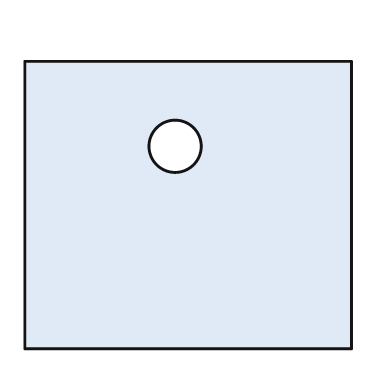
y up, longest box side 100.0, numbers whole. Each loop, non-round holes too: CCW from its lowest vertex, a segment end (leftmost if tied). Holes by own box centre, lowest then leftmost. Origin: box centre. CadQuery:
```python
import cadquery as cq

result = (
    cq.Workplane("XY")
    .moveTo(-50.0, -44.0)
    .lineTo(50.0, -44.0)
    .lineTo(50.0, 44.0)
    .lineTo(-50.0, 44.0)
    .close()
    .moveTo(-4.0, 18.0)
    .circle(8.0)
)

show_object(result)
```